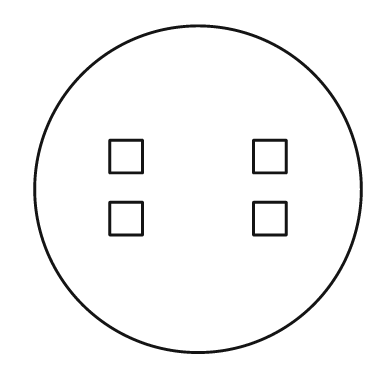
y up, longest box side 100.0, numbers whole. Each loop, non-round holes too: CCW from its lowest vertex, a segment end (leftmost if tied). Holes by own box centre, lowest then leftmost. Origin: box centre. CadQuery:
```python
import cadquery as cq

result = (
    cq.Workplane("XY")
    .moveTo(0.0, 0.0)
    .circle(50.0)
    .moveTo(-27.0, -14.0)
    .lineTo(-17.0, -14.0)
    .lineTo(-17.0, -4.0)
    .lineTo(-27.0, -4.0)
    .close()
    .moveTo(17.0, -14.0)
    .lineTo(27.0, -14.0)
    .lineTo(27.0, -4.0)
    .lineTo(17.0, -4.0)
    .close()
    .moveTo(-27.0, 5.0)
    .lineTo(-17.0, 5.0)
    .lineTo(-17.0, 15.0)
    .lineTo(-27.0, 15.0)
    .close()
    .moveTo(17.0, 5.0)
    .lineTo(27.0, 5.0)
    .lineTo(27.0, 15.0)
    .lineTo(17.0, 15.0)
    .close()
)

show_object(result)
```